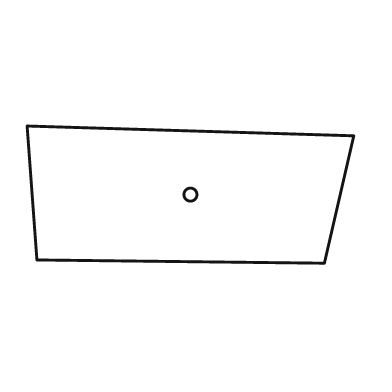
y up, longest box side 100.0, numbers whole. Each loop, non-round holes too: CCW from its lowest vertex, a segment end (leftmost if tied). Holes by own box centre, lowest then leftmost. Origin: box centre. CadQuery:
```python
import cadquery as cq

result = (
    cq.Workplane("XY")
    .moveTo(41.0, -21.0)
    .lineTo(50.0, 18.0)
    .lineTo(-50.0, 21.0)
    .lineTo(-47.0, -20.0)
    .close()
    .moveTo(0.0, 0.0)
    .circle(2.0)
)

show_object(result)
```